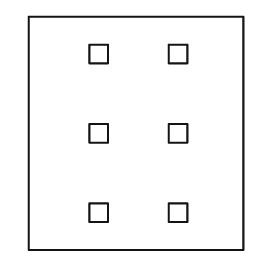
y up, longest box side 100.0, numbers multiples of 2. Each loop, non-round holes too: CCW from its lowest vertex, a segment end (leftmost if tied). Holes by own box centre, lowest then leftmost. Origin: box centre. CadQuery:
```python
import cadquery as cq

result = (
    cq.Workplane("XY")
    .moveTo(-46.0, -50.0)
    .lineTo(46.0, -50.0)
    .lineTo(46.0, 50.0)
    .lineTo(-46.0, 50.0)
    .close()
    .moveTo(-20.0, -38.0)
    .lineTo(-12.0, -38.0)
    .lineTo(-12.0, -30.0)
    .lineTo(-20.0, -30.0)
    .close()
    .moveTo(14.0, -38.0)
    .lineTo(22.0, -38.0)
    .lineTo(22.0, -30.0)
    .lineTo(14.0, -30.0)
    .close()
    .moveTo(-20.0, -4.0)
    .lineTo(-12.0, -4.0)
    .lineTo(-12.0, 4.0)
    .lineTo(-20.0, 4.0)
    .close()
    .moveTo(14.0, -4.0)
    .lineTo(22.0, -4.0)
    .lineTo(22.0, 4.0)
    .lineTo(14.0, 4.0)
    .close()
    .moveTo(-20.0, 30.0)
    .lineTo(-12.0, 30.0)
    .lineTo(-12.0, 38.0)
    .lineTo(-20.0, 38.0)
    .close()
    .moveTo(14.0, 30.0)
    .lineTo(22.0, 30.0)
    .lineTo(22.0, 38.0)
    .lineTo(14.0, 38.0)
    .close()
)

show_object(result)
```